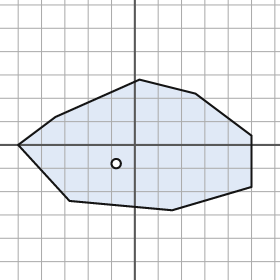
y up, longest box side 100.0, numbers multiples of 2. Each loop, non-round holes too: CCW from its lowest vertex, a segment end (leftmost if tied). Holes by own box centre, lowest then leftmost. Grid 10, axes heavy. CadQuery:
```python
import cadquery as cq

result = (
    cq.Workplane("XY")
    .moveTo(16.0, -28.0)
    .lineTo(50.0, -18.0)
    .lineTo(50.0, 4.0)
    .lineTo(26.0, 22.0)
    .lineTo(2.0, 28.0)
    .lineTo(-34.0, 12.0)
    .lineTo(-50.0, 0.0)
    .lineTo(-28.0, -24.0)
    .close()
    .moveTo(-8.0, -8.0)
    .circle(2.0)
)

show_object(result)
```